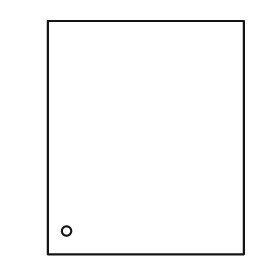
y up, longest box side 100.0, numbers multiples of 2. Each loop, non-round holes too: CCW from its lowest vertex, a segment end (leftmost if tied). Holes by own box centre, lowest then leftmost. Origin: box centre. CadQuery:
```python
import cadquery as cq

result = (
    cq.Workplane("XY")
    .moveTo(-42.0, -50.0)
    .lineTo(42.0, -50.0)
    .lineTo(42.0, 50.0)
    .lineTo(-42.0, 50.0)
    .close()
    .moveTo(-34.0, -40.0)
    .circle(2.0)
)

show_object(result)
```